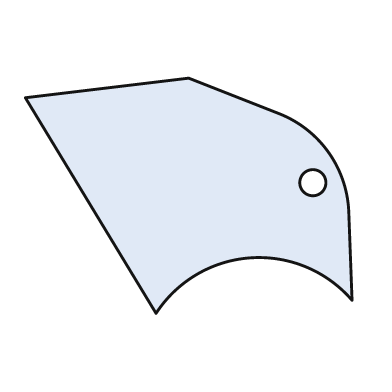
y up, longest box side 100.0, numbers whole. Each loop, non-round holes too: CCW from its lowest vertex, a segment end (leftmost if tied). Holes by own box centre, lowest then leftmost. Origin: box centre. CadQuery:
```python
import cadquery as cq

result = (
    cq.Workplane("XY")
    .moveTo(-10.0, -36.0)
    .threePointArc((19.0, -19.0), (50.0, -32.0))
    .lineTo(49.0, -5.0)
    .threePointArc((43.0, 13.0), (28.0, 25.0))
    .lineTo(0.0, 36.0)
    .lineTo(-50.0, 30.0)
    .close()
    .moveTo(38.0, 4.0)
    .circle(4.0)
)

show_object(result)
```